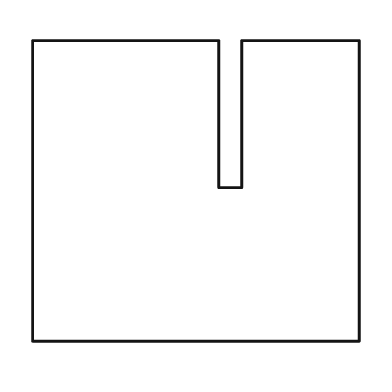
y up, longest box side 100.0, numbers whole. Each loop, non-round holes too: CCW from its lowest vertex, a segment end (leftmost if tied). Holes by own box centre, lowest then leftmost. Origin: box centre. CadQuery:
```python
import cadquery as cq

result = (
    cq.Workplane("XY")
    .moveTo(-50.0, -46.0)
    .lineTo(50.0, -46.0)
    .lineTo(50.0, 46.0)
    .lineTo(14.0, 46.0)
    .lineTo(14.0, 1.0)
    .lineTo(7.0, 1.0)
    .lineTo(7.0, 46.0)
    .lineTo(-50.0, 46.0)
    .close()
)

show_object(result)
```